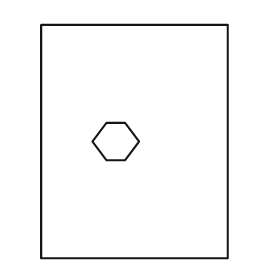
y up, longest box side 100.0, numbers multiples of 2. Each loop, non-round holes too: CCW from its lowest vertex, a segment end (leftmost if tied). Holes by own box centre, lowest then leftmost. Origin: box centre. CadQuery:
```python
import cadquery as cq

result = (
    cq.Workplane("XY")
    .moveTo(-40.0, -50.0)
    .lineTo(40.0, -50.0)
    .lineTo(40.0, 50.0)
    .lineTo(-40.0, 50.0)
    .close()
    .moveTo(-12.0, -8.0)
    .lineTo(-4.0, -8.0)
    .lineTo(2.0, 0.0)
    .lineTo(-4.0, 8.0)
    .lineTo(-12.0, 8.0)
    .lineTo(-18.0, 0.0)
    .close()
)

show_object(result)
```